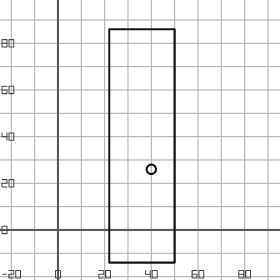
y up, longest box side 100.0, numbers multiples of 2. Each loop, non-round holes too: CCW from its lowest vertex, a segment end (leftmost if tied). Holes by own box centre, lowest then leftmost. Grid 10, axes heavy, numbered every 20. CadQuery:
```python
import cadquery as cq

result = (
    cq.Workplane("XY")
    .moveTo(22.0, -14.0)
    .lineTo(50.0, -14.0)
    .lineTo(50.0, 86.0)
    .lineTo(22.0, 86.0)
    .close()
    .moveTo(40.0, 26.0)
    .circle(2.0)
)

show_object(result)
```